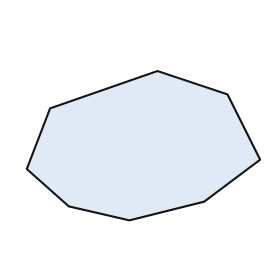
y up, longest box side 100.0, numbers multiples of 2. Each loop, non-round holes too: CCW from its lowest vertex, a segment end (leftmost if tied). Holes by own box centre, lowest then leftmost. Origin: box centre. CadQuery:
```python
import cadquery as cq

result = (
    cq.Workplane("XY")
    .moveTo(-6.0, -32.0)
    .lineTo(26.0, -24.0)
    .lineTo(50.0, -6.0)
    .lineTo(36.0, 22.0)
    .lineTo(6.0, 32.0)
    .lineTo(-40.0, 16.0)
    .lineTo(-50.0, -10.0)
    .lineTo(-32.0, -26.0)
    .close()
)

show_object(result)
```